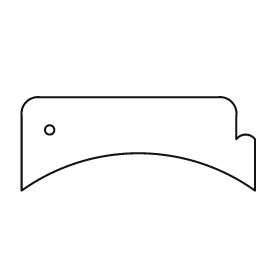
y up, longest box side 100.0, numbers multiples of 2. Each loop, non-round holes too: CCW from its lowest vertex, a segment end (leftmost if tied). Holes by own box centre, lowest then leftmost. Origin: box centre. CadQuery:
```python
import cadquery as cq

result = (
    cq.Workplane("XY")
    .moveTo(-50.0, -20.0)
    .threePointArc((0.0, -4.0), (50.0, -20.0))
    .lineTo(50.0, 2.0)
    .threePointArc((46.0, 4.0), (42.0, 2.0))
    .lineTo(42.0, 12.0)
    .threePointArc((40.0, 18.0), (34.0, 20.0))
    .lineTo(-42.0, 20.0)
    .threePointArc((-48.0, 18.0), (-50.0, 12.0))
    .close()
    .moveTo(-38.0, 6.0)
    .circle(2.0)
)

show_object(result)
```